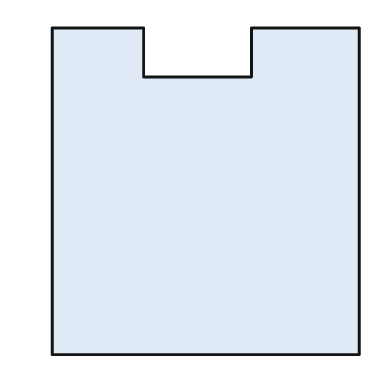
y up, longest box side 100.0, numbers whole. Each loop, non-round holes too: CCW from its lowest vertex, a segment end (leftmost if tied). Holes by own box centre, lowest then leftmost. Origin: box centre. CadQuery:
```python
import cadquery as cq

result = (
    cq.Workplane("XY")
    .moveTo(-47.0, -50.0)
    .lineTo(47.0, -50.0)
    .lineTo(47.0, 50.0)
    .lineTo(14.0, 50.0)
    .lineTo(14.0, 35.0)
    .lineTo(-19.0, 35.0)
    .lineTo(-19.0, 50.0)
    .lineTo(-47.0, 50.0)
    .close()
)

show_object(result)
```